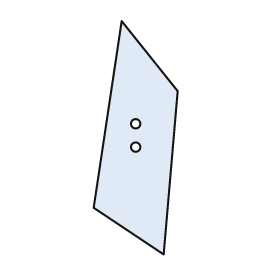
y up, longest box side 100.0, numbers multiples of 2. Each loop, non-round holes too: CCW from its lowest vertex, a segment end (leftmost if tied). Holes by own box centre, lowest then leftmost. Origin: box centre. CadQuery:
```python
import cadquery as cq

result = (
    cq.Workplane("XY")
    .moveTo(12.0, -50.0)
    .lineTo(18.0, 20.0)
    .lineTo(-6.0, 50.0)
    .lineTo(-18.0, -30.0)
    .close()
    .moveTo(0.0, -4.0)
    .circle(2.0)
    .moveTo(0.0, 6.0)
    .circle(2.0)
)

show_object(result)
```